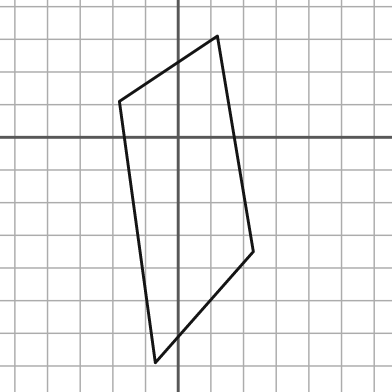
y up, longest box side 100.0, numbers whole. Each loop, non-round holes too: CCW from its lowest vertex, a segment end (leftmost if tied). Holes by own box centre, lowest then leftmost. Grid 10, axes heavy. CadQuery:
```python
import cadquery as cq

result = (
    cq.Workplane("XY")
    .moveTo(-7.0, -69.0)
    .lineTo(23.0, -35.0)
    .lineTo(12.0, 31.0)
    .lineTo(-18.0, 11.0)
    .close()
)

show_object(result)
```